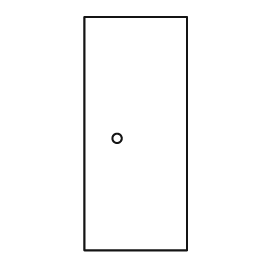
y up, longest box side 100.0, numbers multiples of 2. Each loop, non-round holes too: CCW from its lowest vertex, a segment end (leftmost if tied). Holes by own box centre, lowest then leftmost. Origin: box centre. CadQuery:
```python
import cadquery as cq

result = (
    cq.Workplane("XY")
    .moveTo(-22.0, -50.0)
    .lineTo(22.0, -50.0)
    .lineTo(22.0, 50.0)
    .lineTo(-22.0, 50.0)
    .close()
    .moveTo(-8.0, -2.0)
    .circle(2.0)
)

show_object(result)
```